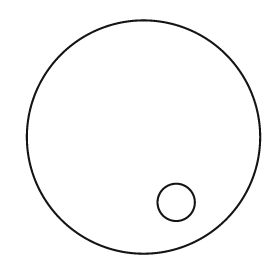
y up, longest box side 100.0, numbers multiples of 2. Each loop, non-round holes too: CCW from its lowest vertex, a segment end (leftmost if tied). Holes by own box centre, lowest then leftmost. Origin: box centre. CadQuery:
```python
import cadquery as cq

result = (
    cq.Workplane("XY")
    .moveTo(0.0, 0.0)
    .circle(50.0)
    .moveTo(14.0, -28.0)
    .circle(8.0)
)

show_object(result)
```